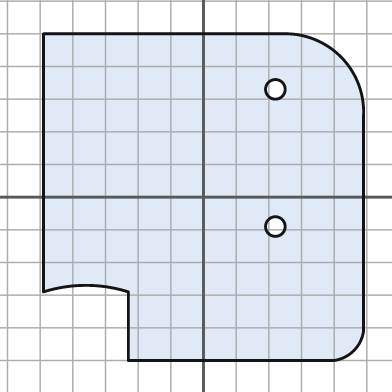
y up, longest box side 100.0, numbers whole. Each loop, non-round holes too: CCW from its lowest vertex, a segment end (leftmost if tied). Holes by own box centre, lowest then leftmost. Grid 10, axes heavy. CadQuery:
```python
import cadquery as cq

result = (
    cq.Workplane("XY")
    .moveTo(-23.0, -50.0)
    .lineTo(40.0, -50.0)
    .threePointArc((46.0, -47.0), (49.0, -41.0))
    .lineTo(49.0, 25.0)
    .threePointArc((42.0, 43.0), (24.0, 50.0))
    .lineTo(-49.0, 50.0)
    .lineTo(-49.0, -29.0)
    .threePointArc((-36.0, -27.0), (-23.0, -29.0))
    .close()
    .moveTo(22.0, -9.0)
    .circle(3.0)
    .moveTo(22.0, 33.0)
    .circle(3.0)
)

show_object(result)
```